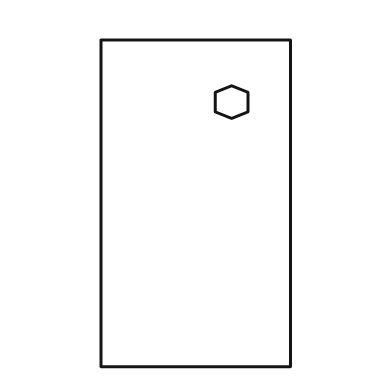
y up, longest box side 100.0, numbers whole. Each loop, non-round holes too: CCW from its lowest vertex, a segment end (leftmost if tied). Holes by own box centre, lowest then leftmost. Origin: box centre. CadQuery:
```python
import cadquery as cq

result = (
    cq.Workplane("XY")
    .moveTo(-29.0, -50.0)
    .lineTo(29.0, -50.0)
    .lineTo(29.0, 50.0)
    .lineTo(-29.0, 50.0)
    .close()
    .moveTo(11.0, 26.0)
    .lineTo(16.0, 28.0)
    .lineTo(16.0, 34.0)
    .lineTo(11.0, 36.0)
    .lineTo(6.0, 34.0)
    .lineTo(6.0, 28.0)
    .close()
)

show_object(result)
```